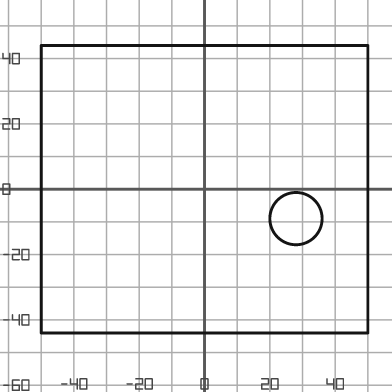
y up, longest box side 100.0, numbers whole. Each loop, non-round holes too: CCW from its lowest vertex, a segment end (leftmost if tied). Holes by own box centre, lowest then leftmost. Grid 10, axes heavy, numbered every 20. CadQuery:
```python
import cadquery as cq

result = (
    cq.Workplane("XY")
    .moveTo(-50.0, -44.0)
    .lineTo(50.0, -44.0)
    .lineTo(50.0, 44.0)
    .lineTo(-50.0, 44.0)
    .close()
    .moveTo(28.0, -9.0)
    .circle(8.0)
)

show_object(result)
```